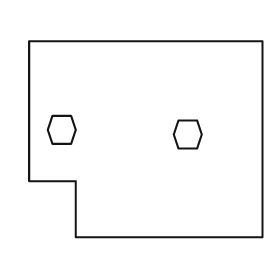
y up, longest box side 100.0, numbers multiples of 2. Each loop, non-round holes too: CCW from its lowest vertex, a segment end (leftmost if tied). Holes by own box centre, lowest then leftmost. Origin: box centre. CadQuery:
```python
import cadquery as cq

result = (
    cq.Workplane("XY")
    .moveTo(-30.0, -42.0)
    .lineTo(50.0, -42.0)
    .lineTo(50.0, 42.0)
    .lineTo(-50.0, 42.0)
    .lineTo(-50.0, -18.0)
    .lineTo(-30.0, -18.0)
    .close()
    .moveTo(14.0, -4.0)
    .lineTo(22.0, -4.0)
    .lineTo(24.0, 2.0)
    .lineTo(22.0, 8.0)
    .lineTo(14.0, 8.0)
    .lineTo(12.0, 2.0)
    .close()
    .moveTo(-40.0, -2.0)
    .lineTo(-32.0, -2.0)
    .lineTo(-30.0, 4.0)
    .lineTo(-32.0, 10.0)
    .lineTo(-40.0, 10.0)
    .lineTo(-42.0, 4.0)
    .close()
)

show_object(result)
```